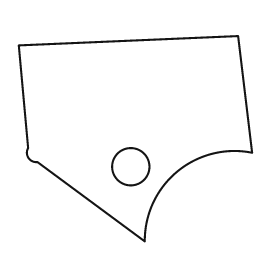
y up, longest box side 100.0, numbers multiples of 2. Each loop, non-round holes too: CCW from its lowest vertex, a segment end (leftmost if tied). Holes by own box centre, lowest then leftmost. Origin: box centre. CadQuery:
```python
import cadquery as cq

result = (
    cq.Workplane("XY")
    .moveTo(4.0, -44.0)
    .threePointArc((18.0, -14.0), (50.0, -6.0))
    .lineTo(44.0, 44.0)
    .lineTo(-50.0, 40.0)
    .lineTo(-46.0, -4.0)
    .threePointArc((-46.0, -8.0), (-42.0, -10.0))
    .close()
    .moveTo(-2.0, -12.0)
    .circle(8.0)
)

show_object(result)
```